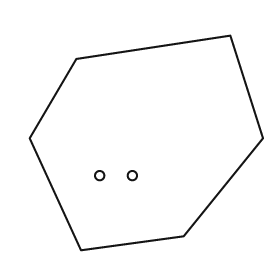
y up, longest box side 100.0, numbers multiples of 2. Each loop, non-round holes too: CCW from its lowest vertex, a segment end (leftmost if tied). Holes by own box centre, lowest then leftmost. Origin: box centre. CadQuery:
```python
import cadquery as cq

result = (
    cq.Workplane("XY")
    .moveTo(-28.0, -46.0)
    .lineTo(16.0, -40.0)
    .lineTo(50.0, 2.0)
    .lineTo(36.0, 46.0)
    .lineTo(-30.0, 36.0)
    .lineTo(-50.0, 2.0)
    .close()
    .moveTo(-20.0, -14.0)
    .circle(2.0)
    .moveTo(-6.0, -14.0)
    .circle(2.0)
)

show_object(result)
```